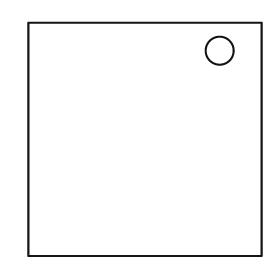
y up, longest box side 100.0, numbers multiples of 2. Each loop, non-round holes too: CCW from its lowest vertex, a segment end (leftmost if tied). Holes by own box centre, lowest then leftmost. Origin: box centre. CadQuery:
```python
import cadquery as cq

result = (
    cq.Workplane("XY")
    .moveTo(-50.0, -50.0)
    .lineTo(50.0, -50.0)
    .lineTo(50.0, 50.0)
    .lineTo(-50.0, 50.0)
    .close()
    .moveTo(32.0, 38.0)
    .circle(6.0)
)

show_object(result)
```